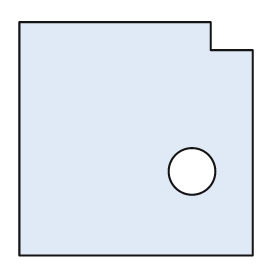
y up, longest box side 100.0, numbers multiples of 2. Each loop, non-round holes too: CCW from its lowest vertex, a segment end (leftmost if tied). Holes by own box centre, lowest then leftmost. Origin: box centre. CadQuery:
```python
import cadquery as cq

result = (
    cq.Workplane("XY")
    .moveTo(-50.0, -50.0)
    .lineTo(50.0, -50.0)
    .lineTo(50.0, 38.0)
    .lineTo(32.0, 38.0)
    .lineTo(32.0, 50.0)
    .lineTo(-50.0, 50.0)
    .close()
    .moveTo(24.0, -14.0)
    .circle(10.0)
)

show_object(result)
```